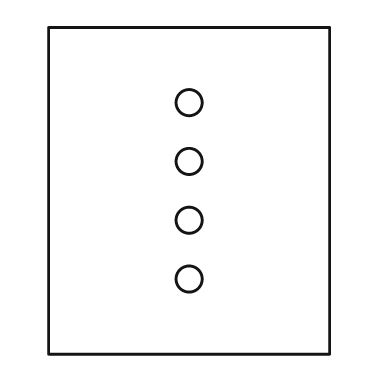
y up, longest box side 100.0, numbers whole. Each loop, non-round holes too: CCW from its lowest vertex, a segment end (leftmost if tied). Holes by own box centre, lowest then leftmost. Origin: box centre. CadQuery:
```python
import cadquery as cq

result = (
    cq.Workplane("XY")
    .moveTo(-43.0, -50.0)
    .lineTo(43.0, -50.0)
    .lineTo(43.0, 50.0)
    .lineTo(-43.0, 50.0)
    .close()
    .moveTo(0.0, -27.0)
    .circle(4.0)
    .moveTo(0.0, -9.0)
    .circle(4.0)
    .moveTo(0.0, 9.0)
    .circle(4.0)
    .moveTo(0.0, 27.0)
    .circle(4.0)
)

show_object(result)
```